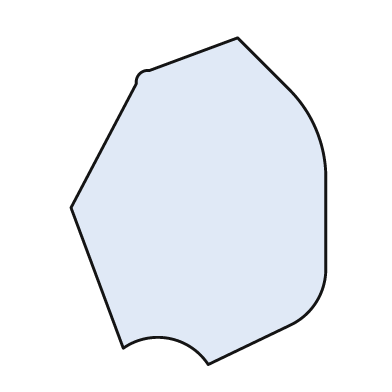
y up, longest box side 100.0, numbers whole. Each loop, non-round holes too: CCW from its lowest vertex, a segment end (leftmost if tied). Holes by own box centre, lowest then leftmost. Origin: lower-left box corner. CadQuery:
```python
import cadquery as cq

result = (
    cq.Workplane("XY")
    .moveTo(42.0, 0.0)
    .lineTo(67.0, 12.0)
    .threePointArc((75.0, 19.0), (78.0, 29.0))
    .lineTo(78.0, 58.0)
    .threePointArc((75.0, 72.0), (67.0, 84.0))
    .lineTo(51.0, 100.0)
    .lineTo(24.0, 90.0)
    .threePointArc((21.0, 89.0), (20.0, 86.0))
    .lineTo(0.0, 48.0)
    .lineTo(16.0, 5.0)
    .threePointArc((30.0, 8.0), (42.0, 0.0))
    .close()
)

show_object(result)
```